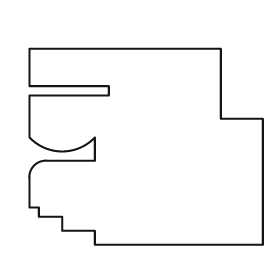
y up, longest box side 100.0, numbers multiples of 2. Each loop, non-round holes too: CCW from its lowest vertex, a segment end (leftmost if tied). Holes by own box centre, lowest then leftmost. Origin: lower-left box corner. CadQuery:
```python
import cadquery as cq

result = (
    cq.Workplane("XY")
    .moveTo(28.0, 0.0)
    .lineTo(100.0, 0.0)
    .lineTo(100.0, 54.0)
    .lineTo(82.0, 54.0)
    .lineTo(82.0, 84.0)
    .lineTo(0.0, 84.0)
    .lineTo(0.0, 68.0)
    .lineTo(34.0, 68.0)
    .lineTo(34.0, 64.0)
    .lineTo(0.0, 64.0)
    .lineTo(0.0, 46.0)
    .threePointArc((14.0, 40.0), (28.0, 46.0))
    .lineTo(28.0, 36.0)
    .lineTo(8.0, 36.0)
    .threePointArc((2.0, 34.0), (0.0, 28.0))
    .lineTo(0.0, 16.0)
    .lineTo(4.0, 16.0)
    .lineTo(4.0, 12.0)
    .lineTo(14.0, 12.0)
    .lineTo(14.0, 6.0)
    .lineTo(28.0, 6.0)
    .close()
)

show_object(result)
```